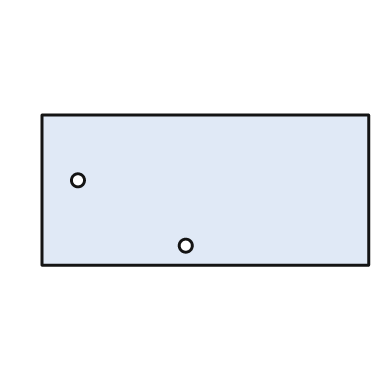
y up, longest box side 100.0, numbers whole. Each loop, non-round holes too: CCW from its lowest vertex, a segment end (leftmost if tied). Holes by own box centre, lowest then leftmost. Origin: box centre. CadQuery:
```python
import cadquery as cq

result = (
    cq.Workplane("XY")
    .moveTo(-50.0, -23.0)
    .lineTo(50.0, -23.0)
    .lineTo(50.0, 23.0)
    .lineTo(-50.0, 23.0)
    .close()
    .moveTo(-6.0, -17.0)
    .circle(2.0)
    .moveTo(-39.0, 3.0)
    .circle(2.0)
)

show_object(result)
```